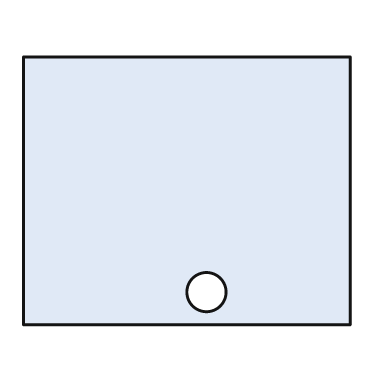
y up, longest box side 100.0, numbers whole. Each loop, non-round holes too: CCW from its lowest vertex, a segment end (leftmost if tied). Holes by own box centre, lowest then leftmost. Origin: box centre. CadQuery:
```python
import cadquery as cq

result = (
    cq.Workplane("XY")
    .moveTo(-50.0, -41.0)
    .lineTo(50.0, -41.0)
    .lineTo(50.0, 41.0)
    .lineTo(-50.0, 41.0)
    .close()
    .moveTo(6.0, -31.0)
    .circle(6.0)
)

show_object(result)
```